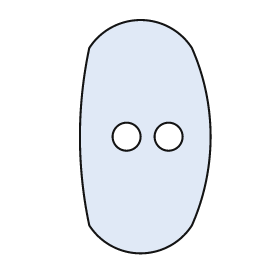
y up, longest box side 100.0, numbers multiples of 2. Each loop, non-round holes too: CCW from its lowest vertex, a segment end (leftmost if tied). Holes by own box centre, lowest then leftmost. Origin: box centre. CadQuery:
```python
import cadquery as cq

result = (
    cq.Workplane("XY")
    .moveTo(-24.0, -38.0)
    .threePointArc((-2.0, -50.0), (20.0, -38.0))
    .threePointArc((28.0, 0.0), (20.0, 38.0))
    .threePointArc((-2.0, 50.0), (-24.0, 38.0))
    .threePointArc((-28.0, 0.0), (-24.0, -38.0))
    .close()
    .moveTo(-8.0, 0.0)
    .circle(6.0)
    .moveTo(10.0, 0.0)
    .circle(6.0)
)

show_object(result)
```